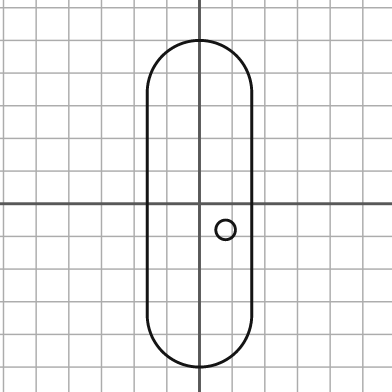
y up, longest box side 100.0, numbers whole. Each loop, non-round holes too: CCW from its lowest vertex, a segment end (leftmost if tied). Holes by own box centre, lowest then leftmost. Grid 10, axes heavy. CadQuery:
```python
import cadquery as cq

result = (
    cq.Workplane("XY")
    .moveTo(-16.0, -34.0)
    .threePointArc((0.0, -50.0), (16.0, -34.0))
    .lineTo(16.0, 34.0)
    .threePointArc((0.0, 50.0), (-16.0, 34.0))
    .close()
    .moveTo(8.0, -8.0)
    .circle(3.0)
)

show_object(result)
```